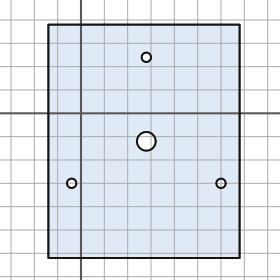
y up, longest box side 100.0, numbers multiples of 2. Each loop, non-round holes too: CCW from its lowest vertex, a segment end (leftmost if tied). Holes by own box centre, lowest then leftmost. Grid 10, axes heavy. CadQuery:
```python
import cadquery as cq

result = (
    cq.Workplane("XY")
    .moveTo(-14.0, -62.0)
    .lineTo(68.0, -62.0)
    .lineTo(68.0, 38.0)
    .lineTo(-14.0, 38.0)
    .close()
    .moveTo(-4.0, -30.0)
    .circle(2.0)
    .moveTo(60.0, -30.0)
    .circle(2.0)
    .moveTo(28.0, -12.0)
    .circle(4.0)
    .moveTo(28.0, 24.0)
    .circle(2.0)
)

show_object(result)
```